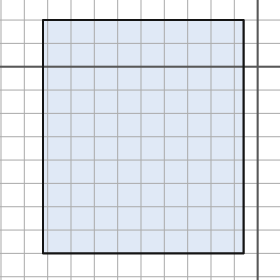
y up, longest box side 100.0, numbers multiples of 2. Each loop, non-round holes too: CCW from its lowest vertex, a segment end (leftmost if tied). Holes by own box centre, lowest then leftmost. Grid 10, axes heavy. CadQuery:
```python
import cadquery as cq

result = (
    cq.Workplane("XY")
    .moveTo(-92.0, -80.0)
    .lineTo(-6.0, -80.0)
    .lineTo(-6.0, 20.0)
    .lineTo(-92.0, 20.0)
    .close()
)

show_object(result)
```